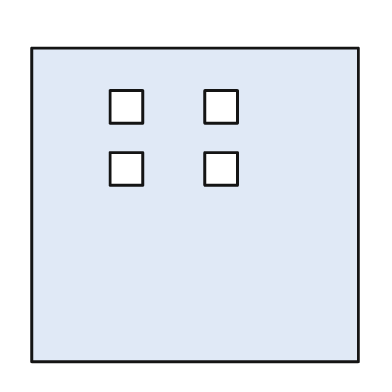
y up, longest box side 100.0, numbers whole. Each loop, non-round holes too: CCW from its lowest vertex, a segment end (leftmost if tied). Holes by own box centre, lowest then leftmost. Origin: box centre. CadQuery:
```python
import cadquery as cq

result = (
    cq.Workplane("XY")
    .moveTo(-50.0, -48.0)
    .lineTo(50.0, -48.0)
    .lineTo(50.0, 48.0)
    .lineTo(-50.0, 48.0)
    .close()
    .moveTo(-26.0, 6.0)
    .lineTo(-16.0, 6.0)
    .lineTo(-16.0, 16.0)
    .lineTo(-26.0, 16.0)
    .close()
    .moveTo(3.0, 6.0)
    .lineTo(13.0, 6.0)
    .lineTo(13.0, 16.0)
    .lineTo(3.0, 16.0)
    .close()
    .moveTo(-26.0, 25.0)
    .lineTo(-16.0, 25.0)
    .lineTo(-16.0, 35.0)
    .lineTo(-26.0, 35.0)
    .close()
    .moveTo(3.0, 25.0)
    .lineTo(13.0, 25.0)
    .lineTo(13.0, 35.0)
    .lineTo(3.0, 35.0)
    .close()
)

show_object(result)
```